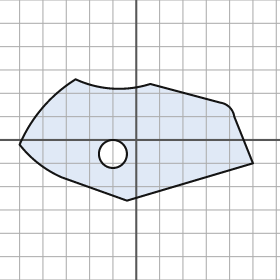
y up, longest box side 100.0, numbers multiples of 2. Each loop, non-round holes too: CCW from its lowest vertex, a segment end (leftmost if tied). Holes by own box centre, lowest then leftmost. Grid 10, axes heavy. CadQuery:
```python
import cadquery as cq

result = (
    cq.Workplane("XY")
    .moveTo(-4.0, -26.0)
    .lineTo(50.0, -10.0)
    .lineTo(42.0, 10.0)
    .threePointArc((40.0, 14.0), (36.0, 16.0))
    .lineTo(6.0, 24.0)
    .threePointArc((-10.0, 22.0), (-26.0, 26.0))
    .threePointArc((-40.0, 14.0), (-50.0, -2.0))
    .threePointArc((-42.0, -10.0), (-32.0, -16.0))
    .close()
    .moveTo(-10.0, -6.0)
    .circle(6.0)
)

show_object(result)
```